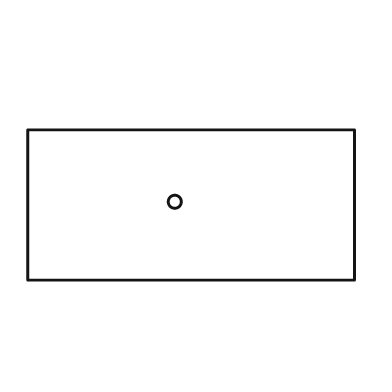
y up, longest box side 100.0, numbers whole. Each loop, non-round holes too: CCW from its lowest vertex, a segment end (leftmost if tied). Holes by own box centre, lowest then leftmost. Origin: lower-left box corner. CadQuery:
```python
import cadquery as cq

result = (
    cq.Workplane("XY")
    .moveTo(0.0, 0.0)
    .lineTo(100.0, 0.0)
    .lineTo(100.0, 46.0)
    .lineTo(0.0, 46.0)
    .close()
    .moveTo(45.0, 24.0)
    .circle(2.0)
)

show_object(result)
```